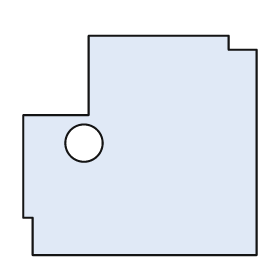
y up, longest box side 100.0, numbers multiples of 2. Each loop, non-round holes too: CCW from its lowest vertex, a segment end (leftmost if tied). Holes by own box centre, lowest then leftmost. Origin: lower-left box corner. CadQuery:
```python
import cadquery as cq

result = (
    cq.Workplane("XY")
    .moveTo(4.0, 0.0)
    .lineTo(100.0, 0.0)
    .lineTo(100.0, 88.0)
    .lineTo(88.0, 88.0)
    .lineTo(88.0, 94.0)
    .lineTo(28.0, 94.0)
    .lineTo(28.0, 60.0)
    .lineTo(0.0, 60.0)
    .lineTo(0.0, 16.0)
    .lineTo(4.0, 16.0)
    .close()
    .moveTo(26.0, 48.0)
    .circle(8.0)
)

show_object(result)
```